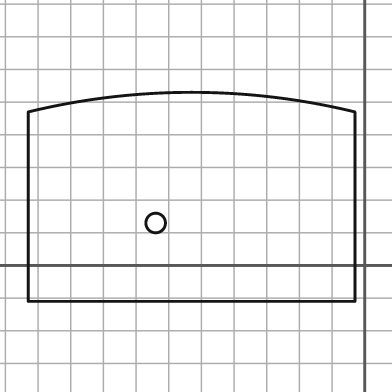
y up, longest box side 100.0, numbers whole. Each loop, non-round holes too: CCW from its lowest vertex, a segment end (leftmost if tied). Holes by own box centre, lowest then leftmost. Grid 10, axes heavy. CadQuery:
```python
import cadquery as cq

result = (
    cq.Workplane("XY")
    .moveTo(-103.0, -11.0)
    .lineTo(-3.0, -11.0)
    .lineTo(-3.0, 47.0)
    .threePointArc((-53.0, 53.0), (-103.0, 47.0))
    .close()
    .moveTo(-64.0, 13.0)
    .circle(3.0)
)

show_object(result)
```